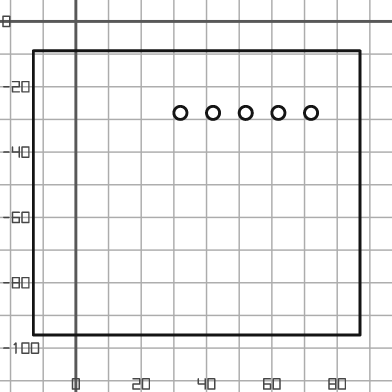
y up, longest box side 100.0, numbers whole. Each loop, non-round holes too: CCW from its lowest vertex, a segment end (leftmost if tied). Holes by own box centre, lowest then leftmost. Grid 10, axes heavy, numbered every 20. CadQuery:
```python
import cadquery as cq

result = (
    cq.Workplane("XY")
    .moveTo(-13.0, -96.0)
    .lineTo(87.0, -96.0)
    .lineTo(87.0, -9.0)
    .lineTo(-13.0, -9.0)
    .close()
    .moveTo(32.0, -28.0)
    .circle(2.0)
    .moveTo(42.0, -28.0)
    .circle(2.0)
    .moveTo(52.0, -28.0)
    .circle(2.0)
    .moveTo(62.0, -28.0)
    .circle(2.0)
    .moveTo(72.0, -28.0)
    .circle(2.0)
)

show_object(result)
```